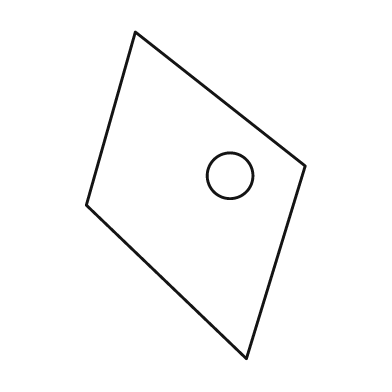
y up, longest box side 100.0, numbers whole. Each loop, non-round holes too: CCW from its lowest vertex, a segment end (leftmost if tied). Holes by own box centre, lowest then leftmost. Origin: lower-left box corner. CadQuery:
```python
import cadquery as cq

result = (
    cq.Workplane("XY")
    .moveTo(49.0, 0.0)
    .lineTo(67.0, 59.0)
    .lineTo(15.0, 100.0)
    .lineTo(0.0, 47.0)
    .close()
    .moveTo(44.0, 56.0)
    .circle(7.0)
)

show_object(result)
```